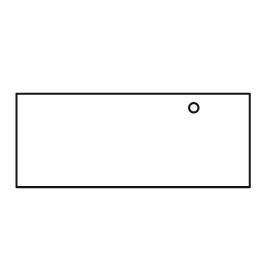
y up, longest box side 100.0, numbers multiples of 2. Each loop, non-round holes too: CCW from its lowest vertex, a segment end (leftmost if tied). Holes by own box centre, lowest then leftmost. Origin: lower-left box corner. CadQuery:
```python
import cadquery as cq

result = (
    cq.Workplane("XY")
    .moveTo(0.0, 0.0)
    .lineTo(100.0, 0.0)
    .lineTo(100.0, 40.0)
    .lineTo(0.0, 40.0)
    .close()
    .moveTo(76.0, 34.0)
    .circle(2.0)
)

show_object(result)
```